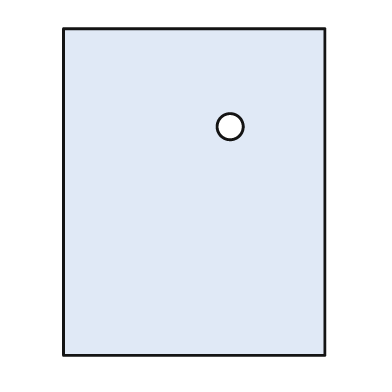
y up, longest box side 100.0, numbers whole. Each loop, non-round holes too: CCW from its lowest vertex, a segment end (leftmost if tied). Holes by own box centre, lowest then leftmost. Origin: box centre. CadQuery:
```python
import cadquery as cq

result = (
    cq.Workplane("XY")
    .moveTo(-40.0, -50.0)
    .lineTo(40.0, -50.0)
    .lineTo(40.0, 50.0)
    .lineTo(-40.0, 50.0)
    .close()
    .moveTo(11.0, 20.0)
    .circle(4.0)
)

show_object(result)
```